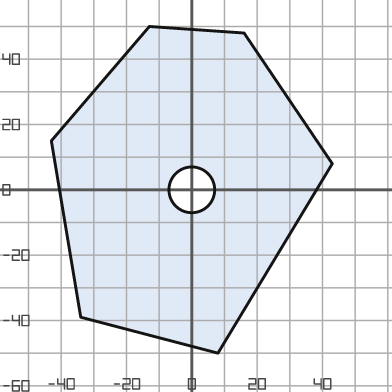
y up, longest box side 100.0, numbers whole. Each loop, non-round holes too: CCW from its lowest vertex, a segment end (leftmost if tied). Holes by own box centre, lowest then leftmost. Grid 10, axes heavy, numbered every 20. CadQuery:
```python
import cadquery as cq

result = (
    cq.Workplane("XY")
    .moveTo(8.0, -50.0)
    .lineTo(43.0, 8.0)
    .lineTo(16.0, 48.0)
    .lineTo(-13.0, 50.0)
    .lineTo(-43.0, 15.0)
    .lineTo(-34.0, -39.0)
    .close()
    .moveTo(0.0, 0.0)
    .circle(7.0)
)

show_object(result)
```